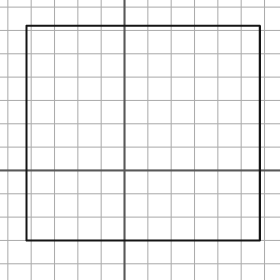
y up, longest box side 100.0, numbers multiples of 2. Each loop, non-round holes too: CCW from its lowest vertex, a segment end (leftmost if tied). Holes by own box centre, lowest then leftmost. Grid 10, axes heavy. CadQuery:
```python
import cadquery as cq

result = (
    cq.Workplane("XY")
    .moveTo(-42.0, -30.0)
    .lineTo(58.0, -30.0)
    .lineTo(58.0, 62.0)
    .lineTo(-42.0, 62.0)
    .close()
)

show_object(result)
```